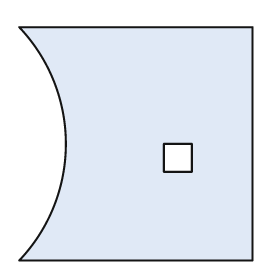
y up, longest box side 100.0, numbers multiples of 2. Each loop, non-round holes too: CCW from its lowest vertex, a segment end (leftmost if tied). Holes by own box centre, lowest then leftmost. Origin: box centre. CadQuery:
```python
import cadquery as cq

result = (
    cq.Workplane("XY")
    .moveTo(-50.0, -50.0)
    .lineTo(50.0, -50.0)
    .lineTo(50.0, 50.0)
    .lineTo(-50.0, 50.0)
    .threePointArc((-30.0, 0.0), (-50.0, -50.0))
    .close()
    .moveTo(12.0, -12.0)
    .lineTo(24.0, -12.0)
    .lineTo(24.0, 0.0)
    .lineTo(12.0, 0.0)
    .close()
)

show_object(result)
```